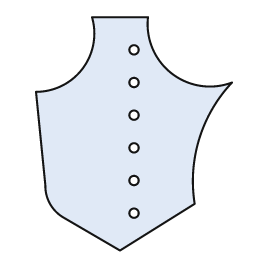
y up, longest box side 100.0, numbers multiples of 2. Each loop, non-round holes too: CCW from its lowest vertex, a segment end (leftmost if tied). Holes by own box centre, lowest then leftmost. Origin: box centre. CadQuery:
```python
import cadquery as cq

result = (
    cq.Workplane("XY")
    .moveTo(-6.0, -50.0)
    .lineTo(26.0, -30.0)
    .threePointArc((28.0, -2.0), (42.0, 22.0))
    .threePointArc((16.0, 26.0), (6.0, 50.0))
    .lineTo(-18.0, 50.0)
    .threePointArc((-22.0, 28.0), (-42.0, 18.0))
    .lineTo(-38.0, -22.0)
    .threePointArc((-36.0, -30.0), (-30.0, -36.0))
    .close()
    .moveTo(0.0, -34.0)
    .circle(2.0)
    .moveTo(0.0, -20.0)
    .circle(2.0)
    .moveTo(0.0, -6.0)
    .circle(2.0)
    .moveTo(0.0, 8.0)
    .circle(2.0)
    .moveTo(0.0, 22.0)
    .circle(2.0)
    .moveTo(0.0, 36.0)
    .circle(2.0)
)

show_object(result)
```